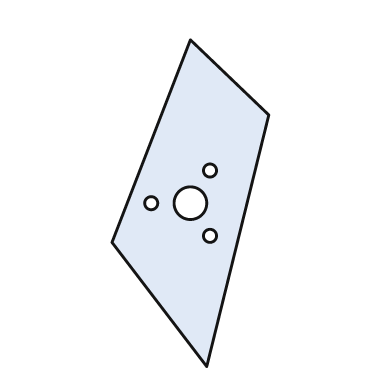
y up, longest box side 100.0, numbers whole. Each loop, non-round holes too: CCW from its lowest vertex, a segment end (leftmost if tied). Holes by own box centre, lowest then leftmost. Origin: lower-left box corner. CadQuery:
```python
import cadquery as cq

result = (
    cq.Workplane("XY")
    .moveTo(29.0, 0.0)
    .lineTo(48.0, 77.0)
    .lineTo(24.0, 100.0)
    .lineTo(0.0, 38.0)
    .close()
    .moveTo(30.0, 40.0)
    .circle(2.0)
    .moveTo(12.0, 50.0)
    .circle(2.0)
    .moveTo(24.0, 50.0)
    .circle(5.0)
    .moveTo(30.0, 60.0)
    .circle(2.0)
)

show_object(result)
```